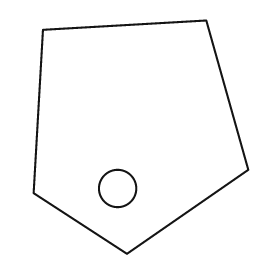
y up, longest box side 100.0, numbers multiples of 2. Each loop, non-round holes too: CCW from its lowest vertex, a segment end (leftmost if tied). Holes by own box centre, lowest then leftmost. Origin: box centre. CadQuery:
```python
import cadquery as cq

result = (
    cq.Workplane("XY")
    .moveTo(-6.0, -50.0)
    .lineTo(46.0, -14.0)
    .lineTo(28.0, 50.0)
    .lineTo(-42.0, 46.0)
    .lineTo(-46.0, -24.0)
    .close()
    .moveTo(-10.0, -22.0)
    .circle(8.0)
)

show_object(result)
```